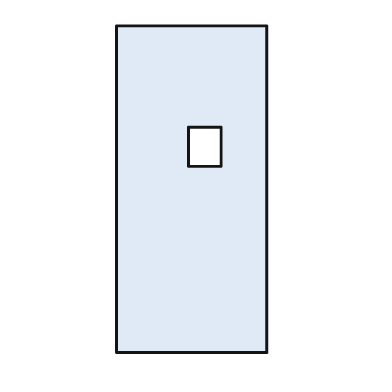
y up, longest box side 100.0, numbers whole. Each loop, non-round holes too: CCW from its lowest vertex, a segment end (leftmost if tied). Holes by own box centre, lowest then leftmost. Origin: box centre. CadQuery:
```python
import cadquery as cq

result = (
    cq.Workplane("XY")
    .moveTo(-23.0, -50.0)
    .lineTo(23.0, -50.0)
    .lineTo(23.0, 50.0)
    .lineTo(-23.0, 50.0)
    .close()
    .moveTo(-1.0, 7.0)
    .lineTo(9.0, 7.0)
    .lineTo(9.0, 19.0)
    .lineTo(-1.0, 19.0)
    .close()
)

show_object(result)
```